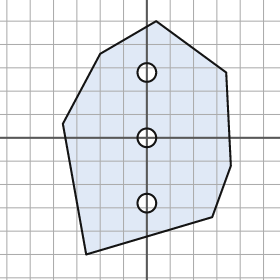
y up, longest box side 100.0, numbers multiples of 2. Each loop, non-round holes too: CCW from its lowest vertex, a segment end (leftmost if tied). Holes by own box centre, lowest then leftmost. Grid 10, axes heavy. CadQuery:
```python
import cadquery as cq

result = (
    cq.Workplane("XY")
    .moveTo(-26.0, -50.0)
    .lineTo(28.0, -34.0)
    .lineTo(36.0, -12.0)
    .lineTo(34.0, 28.0)
    .lineTo(4.0, 50.0)
    .lineTo(-20.0, 36.0)
    .lineTo(-36.0, 6.0)
    .close()
    .moveTo(0.0, -28.0)
    .circle(4.0)
    .moveTo(0.0, 0.0)
    .circle(4.0)
    .moveTo(0.0, 28.0)
    .circle(4.0)
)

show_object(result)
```